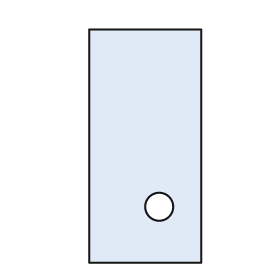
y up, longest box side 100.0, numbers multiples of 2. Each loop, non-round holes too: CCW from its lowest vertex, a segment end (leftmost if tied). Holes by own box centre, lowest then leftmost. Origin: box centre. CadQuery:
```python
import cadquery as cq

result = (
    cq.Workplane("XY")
    .moveTo(-24.0, -50.0)
    .lineTo(24.0, -50.0)
    .lineTo(24.0, 50.0)
    .lineTo(-24.0, 50.0)
    .close()
    .moveTo(6.0, -26.0)
    .circle(6.0)
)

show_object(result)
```